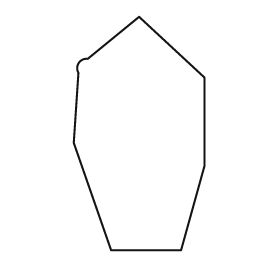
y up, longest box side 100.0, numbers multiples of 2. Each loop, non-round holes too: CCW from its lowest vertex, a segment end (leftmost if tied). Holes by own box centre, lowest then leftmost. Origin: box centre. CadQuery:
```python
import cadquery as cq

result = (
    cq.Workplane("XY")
    .moveTo(-12.0, -50.0)
    .lineTo(18.0, -50.0)
    .lineTo(28.0, -14.0)
    .lineTo(28.0, 24.0)
    .lineTo(0.0, 50.0)
    .lineTo(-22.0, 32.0)
    .threePointArc((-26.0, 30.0), (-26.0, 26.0))
    .lineTo(-28.0, -4.0)
    .close()
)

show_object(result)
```